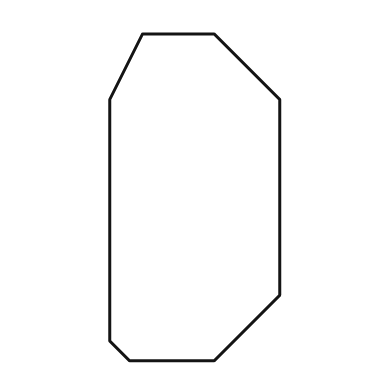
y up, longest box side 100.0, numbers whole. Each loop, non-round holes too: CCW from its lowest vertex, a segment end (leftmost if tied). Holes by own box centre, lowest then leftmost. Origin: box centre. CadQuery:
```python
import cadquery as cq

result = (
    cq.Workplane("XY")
    .moveTo(-20.0, -50.0)
    .lineTo(6.0, -50.0)
    .lineTo(26.0, -30.0)
    .lineTo(26.0, 30.0)
    .lineTo(6.0, 50.0)
    .lineTo(-16.0, 50.0)
    .lineTo(-26.0, 30.0)
    .lineTo(-26.0, -44.0)
    .close()
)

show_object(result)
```